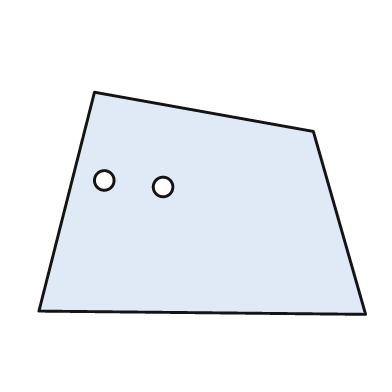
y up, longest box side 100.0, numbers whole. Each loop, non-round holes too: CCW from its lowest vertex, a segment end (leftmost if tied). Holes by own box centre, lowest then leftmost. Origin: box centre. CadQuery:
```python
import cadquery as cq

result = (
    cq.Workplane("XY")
    .moveTo(50.0, -34.0)
    .lineTo(34.0, 22.0)
    .lineTo(-33.0, 34.0)
    .lineTo(-50.0, -33.0)
    .close()
    .moveTo(-12.0, 5.0)
    .circle(3.0)
    .moveTo(-30.0, 7.0)
    .circle(3.0)
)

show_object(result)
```